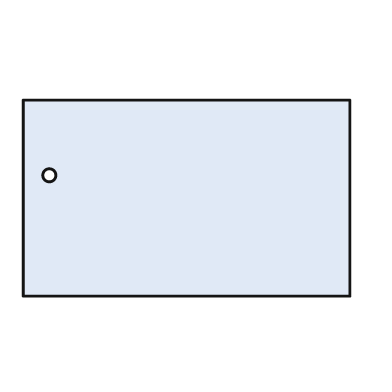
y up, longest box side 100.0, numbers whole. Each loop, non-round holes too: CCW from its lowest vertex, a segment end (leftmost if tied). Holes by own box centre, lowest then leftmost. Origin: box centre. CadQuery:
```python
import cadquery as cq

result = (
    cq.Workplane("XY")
    .moveTo(-50.0, -30.0)
    .lineTo(50.0, -30.0)
    .lineTo(50.0, 30.0)
    .lineTo(-50.0, 30.0)
    .close()
    .moveTo(-42.0, 7.0)
    .circle(2.0)
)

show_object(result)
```